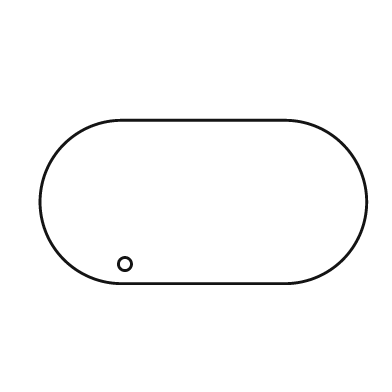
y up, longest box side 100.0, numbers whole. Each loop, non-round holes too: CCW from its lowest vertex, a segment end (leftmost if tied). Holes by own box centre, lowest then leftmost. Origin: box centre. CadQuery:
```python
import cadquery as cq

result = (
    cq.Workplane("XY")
    .moveTo(-25.0, -25.0)
    .lineTo(25.0, -25.0)
    .threePointArc((50.0, 0.0), (25.0, 25.0))
    .lineTo(-25.0, 25.0)
    .threePointArc((-50.0, 0.0), (-25.0, -25.0))
    .close()
    .moveTo(-24.0, -19.0)
    .circle(2.0)
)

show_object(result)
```